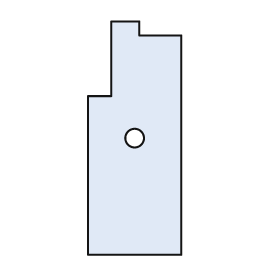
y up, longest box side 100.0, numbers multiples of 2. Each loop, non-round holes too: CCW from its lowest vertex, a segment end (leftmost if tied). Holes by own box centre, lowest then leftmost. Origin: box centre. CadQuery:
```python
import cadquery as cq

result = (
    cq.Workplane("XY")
    .moveTo(-20.0, -50.0)
    .lineTo(20.0, -50.0)
    .lineTo(20.0, 44.0)
    .lineTo(2.0, 44.0)
    .lineTo(2.0, 50.0)
    .lineTo(-10.0, 50.0)
    .lineTo(-10.0, 18.0)
    .lineTo(-20.0, 18.0)
    .close()
    .moveTo(0.0, 0.0)
    .circle(4.0)
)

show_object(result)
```